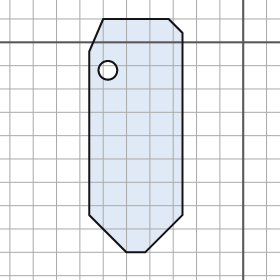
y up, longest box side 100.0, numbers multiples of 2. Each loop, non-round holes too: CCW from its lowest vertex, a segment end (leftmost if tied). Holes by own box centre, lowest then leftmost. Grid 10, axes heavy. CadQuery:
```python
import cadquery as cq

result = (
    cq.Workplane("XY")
    .moveTo(-50.0, -90.0)
    .lineTo(-42.0, -90.0)
    .lineTo(-26.0, -74.0)
    .lineTo(-26.0, 4.0)
    .lineTo(-32.0, 10.0)
    .lineTo(-60.0, 10.0)
    .lineTo(-66.0, -4.0)
    .lineTo(-66.0, -74.0)
    .close()
    .moveTo(-58.0, -12.0)
    .circle(4.0)
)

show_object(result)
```